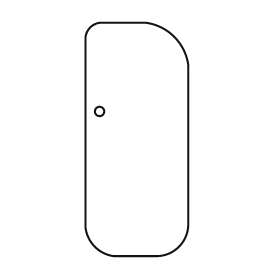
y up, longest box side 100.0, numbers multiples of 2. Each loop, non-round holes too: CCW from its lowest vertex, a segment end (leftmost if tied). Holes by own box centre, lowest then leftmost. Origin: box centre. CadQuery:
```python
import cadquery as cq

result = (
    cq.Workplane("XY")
    .moveTo(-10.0, -50.0)
    .lineTo(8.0, -50.0)
    .threePointArc((18.0, -46.0), (22.0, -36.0))
    .lineTo(22.0, 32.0)
    .threePointArc((16.0, 44.0), (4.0, 50.0))
    .lineTo(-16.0, 50.0)
    .threePointArc((-20.0, 48.0), (-22.0, 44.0))
    .lineTo(-22.0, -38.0)
    .threePointArc((-18.0, -46.0), (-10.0, -50.0))
    .close()
    .moveTo(-16.0, 12.0)
    .circle(2.0)
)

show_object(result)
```